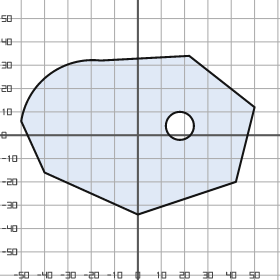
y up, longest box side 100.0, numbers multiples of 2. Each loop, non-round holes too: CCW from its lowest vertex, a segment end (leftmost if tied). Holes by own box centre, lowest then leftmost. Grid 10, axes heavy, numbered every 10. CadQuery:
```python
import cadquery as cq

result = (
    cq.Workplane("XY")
    .moveTo(0.0, -34.0)
    .lineTo(42.0, -20.0)
    .lineTo(50.0, 12.0)
    .lineTo(22.0, 34.0)
    .lineTo(-16.0, 32.0)
    .threePointArc((-38.0, 26.0), (-50.0, 6.0))
    .lineTo(-40.0, -16.0)
    .close()
    .moveTo(18.0, 4.0)
    .circle(6.0)
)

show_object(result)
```